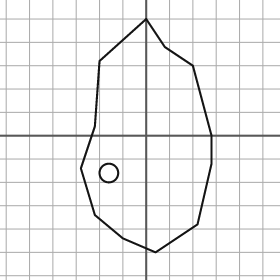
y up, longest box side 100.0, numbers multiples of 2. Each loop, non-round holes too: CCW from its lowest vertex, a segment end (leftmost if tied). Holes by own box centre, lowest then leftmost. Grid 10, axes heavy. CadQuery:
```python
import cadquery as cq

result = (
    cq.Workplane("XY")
    .moveTo(4.0, -50.0)
    .lineTo(22.0, -38.0)
    .lineTo(28.0, -12.0)
    .lineTo(28.0, 0.0)
    .lineTo(20.0, 30.0)
    .lineTo(8.0, 38.0)
    .lineTo(0.0, 50.0)
    .lineTo(-20.0, 32.0)
    .lineTo(-22.0, 4.0)
    .lineTo(-28.0, -14.0)
    .lineTo(-22.0, -34.0)
    .lineTo(-10.0, -44.0)
    .close()
    .moveTo(-16.0, -16.0)
    .circle(4.0)
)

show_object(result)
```